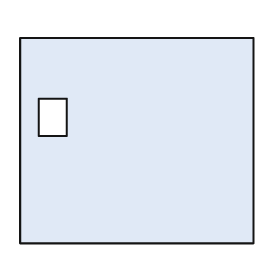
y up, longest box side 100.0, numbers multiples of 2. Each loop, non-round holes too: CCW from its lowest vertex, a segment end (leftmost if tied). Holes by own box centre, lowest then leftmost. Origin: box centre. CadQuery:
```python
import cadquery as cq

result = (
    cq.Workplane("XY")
    .moveTo(-50.0, -44.0)
    .lineTo(50.0, -44.0)
    .lineTo(50.0, 44.0)
    .lineTo(-50.0, 44.0)
    .close()
    .moveTo(-42.0, 2.0)
    .lineTo(-30.0, 2.0)
    .lineTo(-30.0, 18.0)
    .lineTo(-42.0, 18.0)
    .close()
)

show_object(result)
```